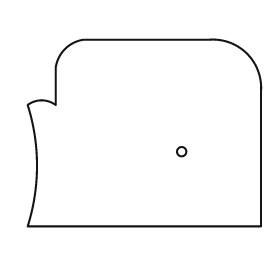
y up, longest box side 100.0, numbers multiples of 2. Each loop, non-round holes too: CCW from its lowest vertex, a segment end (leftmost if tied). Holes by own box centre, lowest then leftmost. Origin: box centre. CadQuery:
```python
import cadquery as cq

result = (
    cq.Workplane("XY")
    .moveTo(-50.0, -40.0)
    .lineTo(50.0, -40.0)
    .lineTo(50.0, 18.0)
    .threePointArc((44.0, 34.0), (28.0, 40.0))
    .lineTo(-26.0, 40.0)
    .threePointArc((-34.0, 36.0), (-38.0, 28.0))
    .lineTo(-38.0, 12.0)
    .threePointArc((-44.0, 14.0), (-50.0, 12.0))
    .threePointArc((-46.0, -14.0), (-50.0, -40.0))
    .close()
    .moveTo(16.0, -8.0)
    .circle(2.0)
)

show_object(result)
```